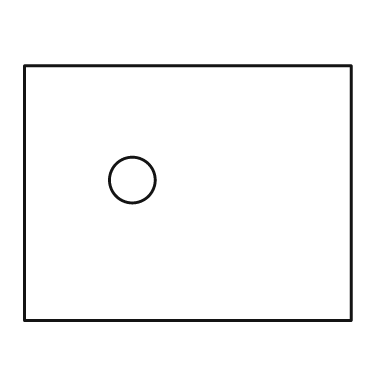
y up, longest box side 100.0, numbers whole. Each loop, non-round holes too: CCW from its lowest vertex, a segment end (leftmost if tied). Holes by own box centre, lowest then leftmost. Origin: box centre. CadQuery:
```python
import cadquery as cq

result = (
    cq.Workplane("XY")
    .moveTo(-50.0, -39.0)
    .lineTo(50.0, -39.0)
    .lineTo(50.0, 39.0)
    .lineTo(-50.0, 39.0)
    .close()
    .moveTo(-17.0, 4.0)
    .circle(7.0)
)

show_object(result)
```